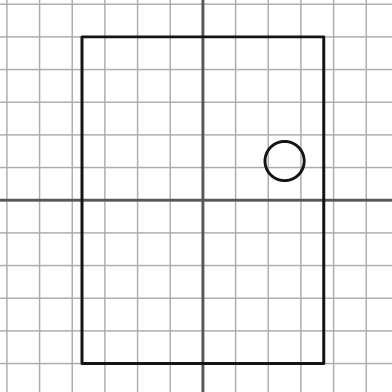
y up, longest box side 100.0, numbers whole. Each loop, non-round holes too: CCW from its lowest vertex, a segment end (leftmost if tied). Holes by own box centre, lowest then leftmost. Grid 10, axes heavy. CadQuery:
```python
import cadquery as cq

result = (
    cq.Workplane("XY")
    .moveTo(-37.0, -50.0)
    .lineTo(37.0, -50.0)
    .lineTo(37.0, 50.0)
    .lineTo(-37.0, 50.0)
    .close()
    .moveTo(25.0, 12.0)
    .circle(6.0)
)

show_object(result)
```